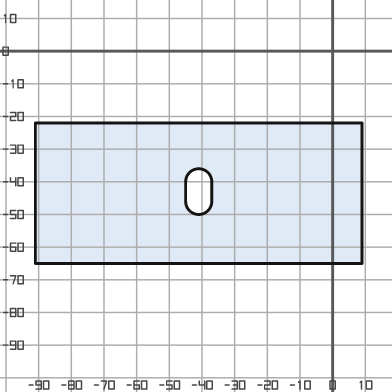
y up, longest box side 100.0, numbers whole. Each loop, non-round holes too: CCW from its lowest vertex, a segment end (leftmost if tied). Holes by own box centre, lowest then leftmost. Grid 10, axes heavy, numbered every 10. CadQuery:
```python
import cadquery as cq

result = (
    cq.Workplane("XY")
    .moveTo(-91.0, -65.0)
    .lineTo(9.0, -65.0)
    .lineTo(9.0, -22.0)
    .lineTo(-91.0, -22.0)
    .close()
    .moveTo(-45.0, -46.0)
    .threePointArc((-41.0, -50.0), (-37.0, -46.0))
    .lineTo(-37.0, -40.0)
    .threePointArc((-41.0, -36.0), (-45.0, -40.0))
    .close()
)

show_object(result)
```